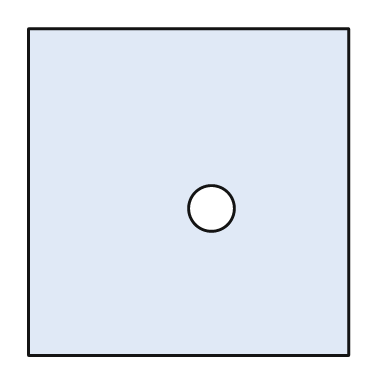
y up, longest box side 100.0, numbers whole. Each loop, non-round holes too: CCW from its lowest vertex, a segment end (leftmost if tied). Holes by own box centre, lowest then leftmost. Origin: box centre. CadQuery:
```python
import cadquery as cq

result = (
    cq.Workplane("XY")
    .moveTo(-49.0, -50.0)
    .lineTo(49.0, -50.0)
    .lineTo(49.0, 50.0)
    .lineTo(-49.0, 50.0)
    .close()
    .moveTo(7.0, -5.0)
    .circle(7.0)
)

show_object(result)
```